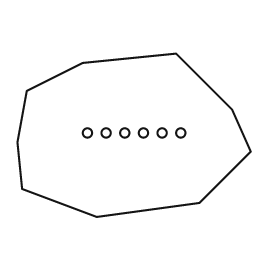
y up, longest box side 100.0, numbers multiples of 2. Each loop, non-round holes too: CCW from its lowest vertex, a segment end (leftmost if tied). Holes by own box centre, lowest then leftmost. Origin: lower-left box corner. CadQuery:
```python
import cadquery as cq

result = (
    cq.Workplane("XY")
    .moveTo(34.0, 0.0)
    .lineTo(78.0, 6.0)
    .lineTo(100.0, 28.0)
    .lineTo(92.0, 46.0)
    .lineTo(68.0, 70.0)
    .lineTo(28.0, 66.0)
    .lineTo(4.0, 54.0)
    .lineTo(0.0, 32.0)
    .lineTo(2.0, 12.0)
    .close()
    .moveTo(30.0, 36.0)
    .circle(2.0)
    .moveTo(38.0, 36.0)
    .circle(2.0)
    .moveTo(46.0, 36.0)
    .circle(2.0)
    .moveTo(54.0, 36.0)
    .circle(2.0)
    .moveTo(62.0, 36.0)
    .circle(2.0)
    .moveTo(70.0, 36.0)
    .circle(2.0)
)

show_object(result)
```